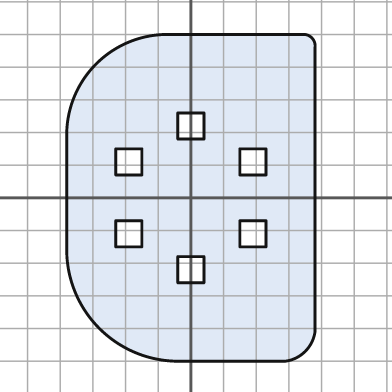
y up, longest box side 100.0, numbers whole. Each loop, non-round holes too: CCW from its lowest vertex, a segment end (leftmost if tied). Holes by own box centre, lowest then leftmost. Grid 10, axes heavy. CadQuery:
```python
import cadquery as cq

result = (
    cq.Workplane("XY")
    .moveTo(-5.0, -50.0)
    .lineTo(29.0, -50.0)
    .threePointArc((35.0, -47.0), (38.0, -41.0))
    .lineTo(38.0, 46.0)
    .threePointArc((37.0, 49.0), (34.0, 50.0))
    .lineTo(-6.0, 50.0)
    .threePointArc((-29.0, 41.0), (-38.0, 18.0))
    .lineTo(-38.0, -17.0)
    .threePointArc((-28.0, -40.0), (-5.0, -50.0))
    .close()
    .moveTo(-4.0, -26.0)
    .lineTo(4.0, -26.0)
    .lineTo(4.0, -18.0)
    .lineTo(-4.0, -18.0)
    .close()
    .moveTo(-23.0, -15.0)
    .lineTo(-15.0, -15.0)
    .lineTo(-15.0, -7.0)
    .lineTo(-23.0, -7.0)
    .close()
    .moveTo(15.0, -15.0)
    .lineTo(23.0, -15.0)
    .lineTo(23.0, -7.0)
    .lineTo(15.0, -7.0)
    .close()
    .moveTo(-23.0, 7.0)
    .lineTo(-15.0, 7.0)
    .lineTo(-15.0, 15.0)
    .lineTo(-23.0, 15.0)
    .close()
    .moveTo(15.0, 7.0)
    .lineTo(23.0, 7.0)
    .lineTo(23.0, 15.0)
    .lineTo(15.0, 15.0)
    .close()
    .moveTo(-4.0, 18.0)
    .lineTo(4.0, 18.0)
    .lineTo(4.0, 26.0)
    .lineTo(-4.0, 26.0)
    .close()
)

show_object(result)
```